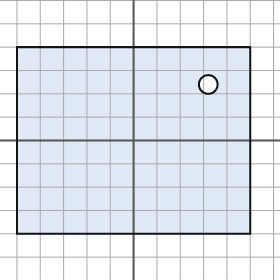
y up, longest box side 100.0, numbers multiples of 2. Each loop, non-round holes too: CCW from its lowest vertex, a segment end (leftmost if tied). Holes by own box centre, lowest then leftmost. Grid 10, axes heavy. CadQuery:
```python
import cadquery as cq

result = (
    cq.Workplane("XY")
    .moveTo(-50.0, -40.0)
    .lineTo(50.0, -40.0)
    .lineTo(50.0, 40.0)
    .lineTo(-50.0, 40.0)
    .close()
    .moveTo(32.0, 24.0)
    .circle(4.0)
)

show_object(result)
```